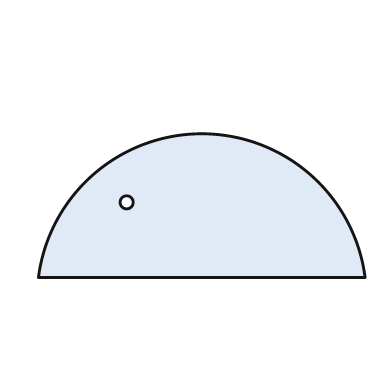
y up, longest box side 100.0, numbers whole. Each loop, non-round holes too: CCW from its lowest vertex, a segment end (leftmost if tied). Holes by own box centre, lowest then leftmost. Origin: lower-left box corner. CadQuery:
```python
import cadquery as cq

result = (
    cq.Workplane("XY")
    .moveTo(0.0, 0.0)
    .lineTo(100.0, 0.0)
    .threePointArc((50.0, 44.0), (0.0, 0.0))
    .close()
    .moveTo(27.0, 23.0)
    .circle(2.0)
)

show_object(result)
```